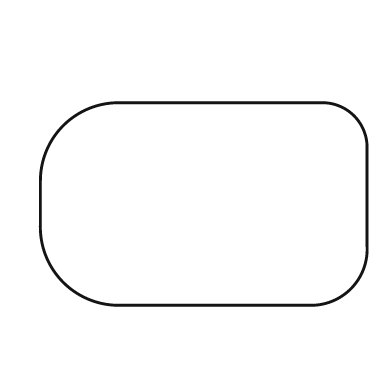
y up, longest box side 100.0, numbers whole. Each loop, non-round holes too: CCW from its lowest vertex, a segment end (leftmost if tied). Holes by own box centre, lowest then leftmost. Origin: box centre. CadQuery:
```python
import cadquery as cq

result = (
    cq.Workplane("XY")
    .moveTo(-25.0, -31.0)
    .lineTo(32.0, -31.0)
    .threePointArc((45.0, -26.0), (50.0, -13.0))
    .lineTo(50.0, 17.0)
    .threePointArc((46.0, 27.0), (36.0, 31.0))
    .lineTo(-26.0, 31.0)
    .threePointArc((-43.0, 24.0), (-50.0, 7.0))
    .lineTo(-50.0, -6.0)
    .threePointArc((-43.0, -24.0), (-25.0, -31.0))
    .close()
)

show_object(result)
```